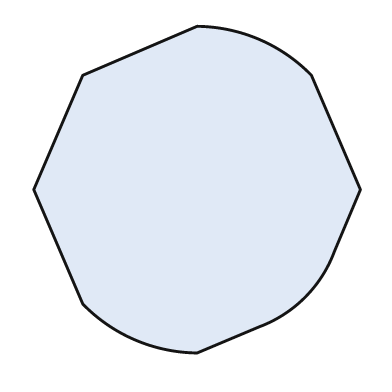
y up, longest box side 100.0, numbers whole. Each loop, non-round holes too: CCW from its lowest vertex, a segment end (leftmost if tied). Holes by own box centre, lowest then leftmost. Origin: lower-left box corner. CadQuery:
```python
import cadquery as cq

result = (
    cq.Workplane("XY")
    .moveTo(50.0, 0.0)
    .lineTo(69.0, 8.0)
    .threePointArc((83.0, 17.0), (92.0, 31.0))
    .lineTo(100.0, 50.0)
    .lineTo(85.0, 85.0)
    .threePointArc((69.0, 96.0), (50.0, 100.0))
    .lineTo(15.0, 85.0)
    .lineTo(0.0, 50.0)
    .lineTo(15.0, 15.0)
    .threePointArc((31.0, 4.0), (50.0, 0.0))
    .close()
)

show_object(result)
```